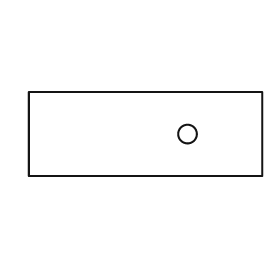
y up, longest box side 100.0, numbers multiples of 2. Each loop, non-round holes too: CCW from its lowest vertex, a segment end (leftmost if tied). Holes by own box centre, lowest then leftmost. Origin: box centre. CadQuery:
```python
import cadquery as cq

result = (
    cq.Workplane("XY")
    .moveTo(-50.0, -18.0)
    .lineTo(50.0, -18.0)
    .lineTo(50.0, 18.0)
    .lineTo(-50.0, 18.0)
    .close()
    .moveTo(18.0, 0.0)
    .circle(4.0)
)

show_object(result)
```